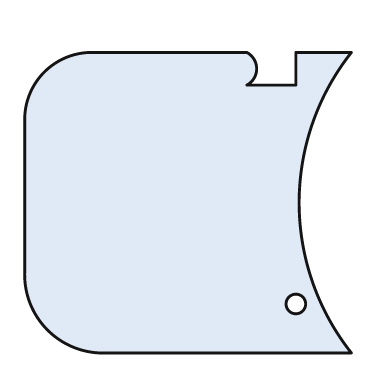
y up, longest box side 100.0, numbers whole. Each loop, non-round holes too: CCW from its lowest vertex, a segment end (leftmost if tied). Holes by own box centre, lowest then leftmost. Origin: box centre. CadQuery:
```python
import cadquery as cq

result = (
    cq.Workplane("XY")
    .moveTo(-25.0, -46.0)
    .lineTo(50.0, -46.0)
    .threePointArc((34.0, 0.0), (50.0, 46.0))
    .lineTo(33.0, 46.0)
    .lineTo(33.0, 36.0)
    .lineTo(18.0, 36.0)
    .threePointArc((21.0, 41.0), (18.0, 46.0))
    .lineTo(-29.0, 46.0)
    .threePointArc((-44.0, 40.0), (-50.0, 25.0))
    .lineTo(-50.0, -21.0)
    .threePointArc((-43.0, -39.0), (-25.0, -46.0))
    .close()
    .moveTo(33.0, -31.0)
    .circle(3.0)
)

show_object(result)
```